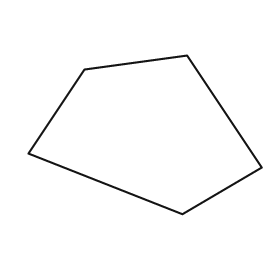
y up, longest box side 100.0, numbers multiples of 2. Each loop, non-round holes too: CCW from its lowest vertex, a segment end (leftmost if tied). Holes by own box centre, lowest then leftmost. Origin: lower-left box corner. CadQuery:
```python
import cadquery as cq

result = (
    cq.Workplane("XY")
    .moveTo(66.0, 0.0)
    .lineTo(100.0, 20.0)
    .lineTo(68.0, 68.0)
    .lineTo(24.0, 62.0)
    .lineTo(0.0, 26.0)
    .close()
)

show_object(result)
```